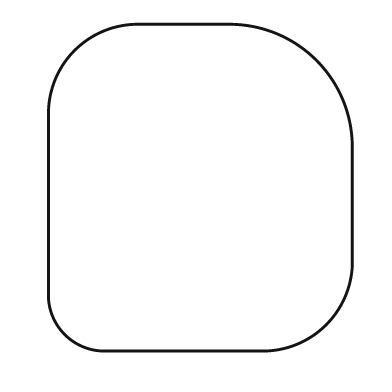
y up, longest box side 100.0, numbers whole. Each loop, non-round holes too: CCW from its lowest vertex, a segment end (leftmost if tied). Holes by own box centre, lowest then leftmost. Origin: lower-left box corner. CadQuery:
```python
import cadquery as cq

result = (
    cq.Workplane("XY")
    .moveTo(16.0, 0.0)
    .lineTo(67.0, 0.0)
    .threePointArc((85.0, 8.0), (93.0, 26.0))
    .lineTo(93.0, 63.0)
    .threePointArc((82.0, 89.0), (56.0, 100.0))
    .lineTo(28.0, 100.0)
    .threePointArc((8.0, 92.0), (0.0, 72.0))
    .lineTo(0.0, 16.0)
    .threePointArc((5.0, 5.0), (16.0, 0.0))
    .close()
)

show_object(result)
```